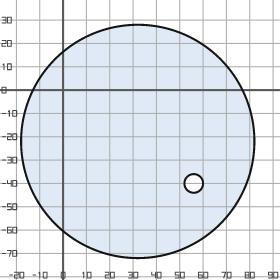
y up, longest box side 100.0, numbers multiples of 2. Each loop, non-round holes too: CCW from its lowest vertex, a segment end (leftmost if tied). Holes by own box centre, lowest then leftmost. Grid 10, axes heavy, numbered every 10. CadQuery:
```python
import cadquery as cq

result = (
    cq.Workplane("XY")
    .moveTo(32.0, -22.0)
    .circle(50.0)
    .moveTo(56.0, -40.0)
    .circle(4.0)
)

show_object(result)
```